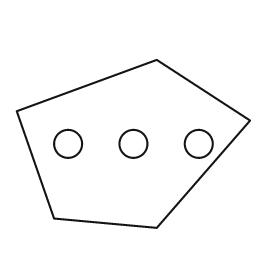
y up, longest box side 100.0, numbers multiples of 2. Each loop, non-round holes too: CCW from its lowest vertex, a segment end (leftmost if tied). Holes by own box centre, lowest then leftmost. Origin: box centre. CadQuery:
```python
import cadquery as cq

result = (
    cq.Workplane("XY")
    .moveTo(10.0, -36.0)
    .lineTo(50.0, 10.0)
    .lineTo(10.0, 36.0)
    .lineTo(-50.0, 14.0)
    .lineTo(-34.0, -32.0)
    .close()
    .moveTo(-28.0, 0.0)
    .circle(6.0)
    .moveTo(0.0, 0.0)
    .circle(6.0)
    .moveTo(28.0, 0.0)
    .circle(6.0)
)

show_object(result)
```